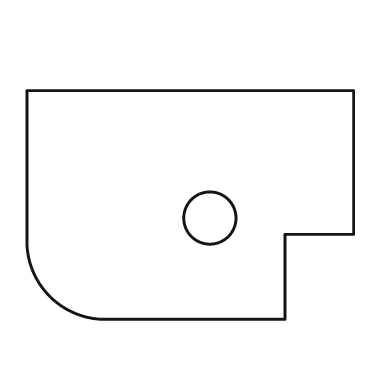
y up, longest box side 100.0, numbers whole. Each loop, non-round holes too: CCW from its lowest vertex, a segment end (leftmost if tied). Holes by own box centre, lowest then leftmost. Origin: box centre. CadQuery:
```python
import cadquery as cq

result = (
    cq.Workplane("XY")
    .moveTo(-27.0, -35.0)
    .lineTo(29.0, -35.0)
    .lineTo(29.0, -9.0)
    .lineTo(50.0, -9.0)
    .lineTo(50.0, 35.0)
    .lineTo(-50.0, 35.0)
    .lineTo(-50.0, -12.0)
    .threePointArc((-43.0, -28.0), (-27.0, -35.0))
    .close()
    .moveTo(6.0, -4.0)
    .circle(8.0)
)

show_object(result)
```